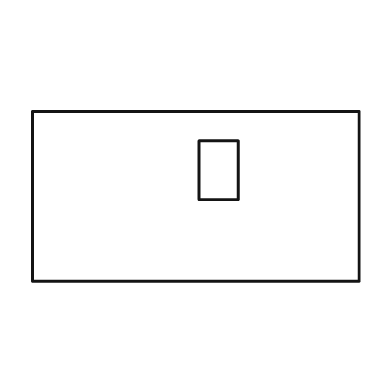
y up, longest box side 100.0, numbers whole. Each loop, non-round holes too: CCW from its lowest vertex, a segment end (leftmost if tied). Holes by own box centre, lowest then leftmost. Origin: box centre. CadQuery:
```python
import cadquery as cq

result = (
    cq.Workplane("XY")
    .moveTo(-50.0, -26.0)
    .lineTo(50.0, -26.0)
    .lineTo(50.0, 26.0)
    .lineTo(-50.0, 26.0)
    .close()
    .moveTo(1.0, -1.0)
    .lineTo(13.0, -1.0)
    .lineTo(13.0, 17.0)
    .lineTo(1.0, 17.0)
    .close()
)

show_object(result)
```